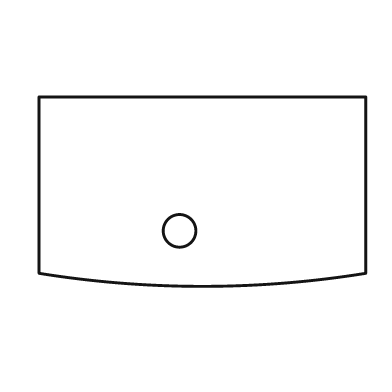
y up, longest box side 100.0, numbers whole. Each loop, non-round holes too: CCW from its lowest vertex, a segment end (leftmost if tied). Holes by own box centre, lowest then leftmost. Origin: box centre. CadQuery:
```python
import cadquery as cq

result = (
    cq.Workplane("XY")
    .moveTo(-50.0, -25.0)
    .threePointArc((0.0, -29.0), (50.0, -25.0))
    .lineTo(50.0, 29.0)
    .lineTo(-50.0, 29.0)
    .close()
    .moveTo(-7.0, -12.0)
    .circle(5.0)
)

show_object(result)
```